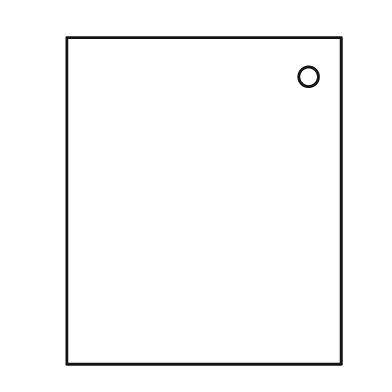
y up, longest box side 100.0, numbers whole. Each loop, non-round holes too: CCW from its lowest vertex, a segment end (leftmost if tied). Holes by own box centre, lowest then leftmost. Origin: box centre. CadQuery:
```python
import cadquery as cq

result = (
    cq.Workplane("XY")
    .moveTo(-42.0, -50.0)
    .lineTo(42.0, -50.0)
    .lineTo(42.0, 50.0)
    .lineTo(-42.0, 50.0)
    .close()
    .moveTo(32.0, 38.0)
    .circle(3.0)
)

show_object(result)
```